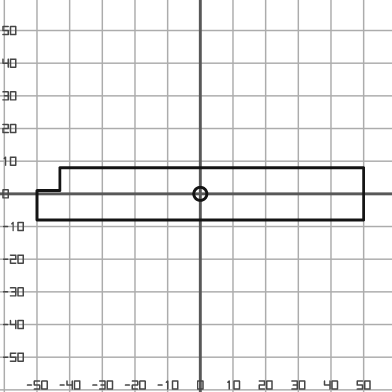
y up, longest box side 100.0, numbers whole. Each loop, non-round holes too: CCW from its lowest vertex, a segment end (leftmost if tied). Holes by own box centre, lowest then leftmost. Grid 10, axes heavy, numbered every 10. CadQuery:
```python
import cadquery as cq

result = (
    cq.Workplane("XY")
    .moveTo(-50.0, -8.0)
    .lineTo(50.0, -8.0)
    .lineTo(50.0, 8.0)
    .lineTo(-43.0, 8.0)
    .lineTo(-43.0, 1.0)
    .lineTo(-50.0, 1.0)
    .close()
    .moveTo(0.0, 0.0)
    .circle(2.0)
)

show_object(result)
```